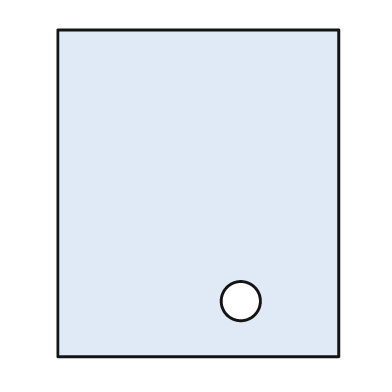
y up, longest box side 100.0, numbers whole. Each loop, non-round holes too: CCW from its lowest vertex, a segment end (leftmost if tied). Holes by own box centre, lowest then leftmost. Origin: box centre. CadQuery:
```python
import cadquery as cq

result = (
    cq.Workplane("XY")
    .moveTo(-43.0, -50.0)
    .lineTo(43.0, -50.0)
    .lineTo(43.0, 50.0)
    .lineTo(-43.0, 50.0)
    .close()
    .moveTo(13.0, -33.0)
    .circle(6.0)
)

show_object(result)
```